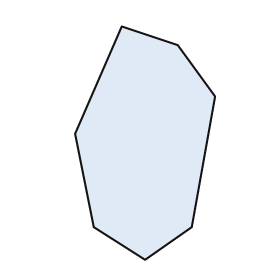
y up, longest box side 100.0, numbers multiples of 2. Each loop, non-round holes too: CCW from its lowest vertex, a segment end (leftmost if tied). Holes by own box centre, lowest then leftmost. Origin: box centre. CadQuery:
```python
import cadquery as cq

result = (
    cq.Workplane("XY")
    .moveTo(0.0, -50.0)
    .lineTo(20.0, -36.0)
    .lineTo(30.0, 20.0)
    .lineTo(14.0, 42.0)
    .lineTo(-10.0, 50.0)
    .lineTo(-30.0, 4.0)
    .lineTo(-22.0, -36.0)
    .close()
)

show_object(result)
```